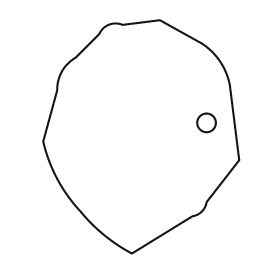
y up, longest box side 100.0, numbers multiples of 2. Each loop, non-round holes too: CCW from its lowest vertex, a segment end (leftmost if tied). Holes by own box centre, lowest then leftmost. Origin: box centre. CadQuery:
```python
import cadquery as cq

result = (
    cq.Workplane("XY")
    .moveTo(-4.0, -50.0)
    .lineTo(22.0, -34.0)
    .threePointArc((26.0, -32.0), (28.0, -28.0))
    .lineTo(42.0, -10.0)
    .lineTo(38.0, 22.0)
    .threePointArc((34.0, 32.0), (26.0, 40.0))
    .lineTo(8.0, 50.0)
    .lineTo(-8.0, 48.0)
    .threePointArc((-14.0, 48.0), (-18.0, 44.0))
    .lineTo(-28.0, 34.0)
    .threePointArc((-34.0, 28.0), (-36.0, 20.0))
    .lineTo(-42.0, -2.0)
    .threePointArc((-36.0, -18.0), (-26.0, -32.0))
    .threePointArc((-16.0, -42.0), (-4.0, -50.0))
    .close()
    .moveTo(28.0, 6.0)
    .circle(4.0)
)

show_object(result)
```